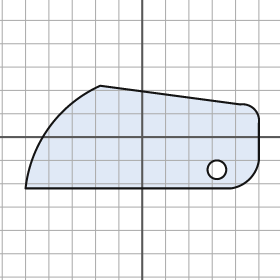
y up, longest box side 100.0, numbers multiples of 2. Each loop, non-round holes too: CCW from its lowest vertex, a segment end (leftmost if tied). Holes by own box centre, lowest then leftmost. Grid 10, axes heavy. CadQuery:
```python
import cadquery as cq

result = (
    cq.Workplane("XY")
    .moveTo(-50.0, -22.0)
    .lineTo(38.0, -22.0)
    .threePointArc((46.0, -18.0), (50.0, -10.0))
    .lineTo(50.0, 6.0)
    .threePointArc((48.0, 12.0), (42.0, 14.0))
    .lineTo(-18.0, 22.0)
    .threePointArc((-40.0, 4.0), (-50.0, -22.0))
    .close()
    .moveTo(32.0, -14.0)
    .circle(4.0)
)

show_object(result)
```